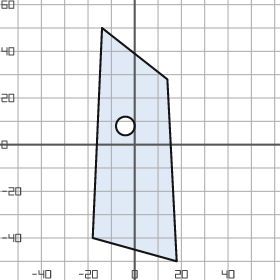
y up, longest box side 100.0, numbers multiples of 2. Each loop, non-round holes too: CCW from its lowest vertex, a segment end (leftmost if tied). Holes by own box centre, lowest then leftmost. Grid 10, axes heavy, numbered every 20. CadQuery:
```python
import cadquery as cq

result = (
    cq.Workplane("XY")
    .moveTo(18.0, -50.0)
    .lineTo(14.0, 28.0)
    .lineTo(-14.0, 50.0)
    .lineTo(-18.0, -40.0)
    .close()
    .moveTo(-4.0, 8.0)
    .circle(4.0)
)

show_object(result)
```